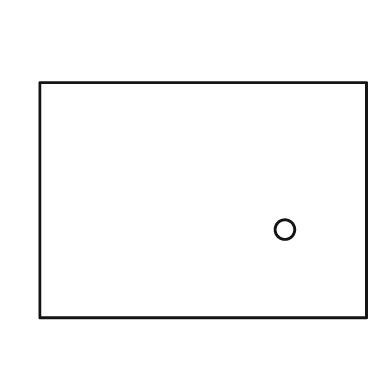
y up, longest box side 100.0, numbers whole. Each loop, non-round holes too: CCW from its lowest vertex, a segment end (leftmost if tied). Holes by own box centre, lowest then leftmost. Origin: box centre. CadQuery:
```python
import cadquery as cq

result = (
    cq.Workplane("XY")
    .moveTo(-50.0, -36.0)
    .lineTo(50.0, -36.0)
    .lineTo(50.0, 36.0)
    .lineTo(-50.0, 36.0)
    .close()
    .moveTo(25.0, -9.0)
    .circle(3.0)
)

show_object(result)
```